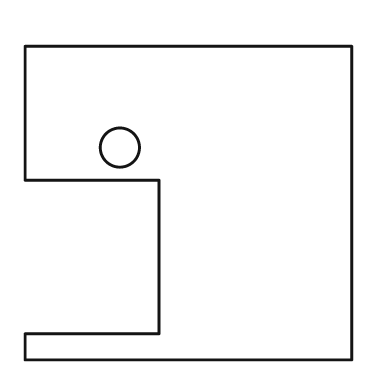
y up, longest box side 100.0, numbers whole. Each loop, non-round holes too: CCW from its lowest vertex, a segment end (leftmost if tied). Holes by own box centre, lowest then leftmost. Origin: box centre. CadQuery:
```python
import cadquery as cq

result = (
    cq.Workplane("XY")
    .moveTo(-50.0, -48.0)
    .lineTo(50.0, -48.0)
    .lineTo(50.0, 48.0)
    .lineTo(-50.0, 48.0)
    .lineTo(-50.0, 7.0)
    .lineTo(-9.0, 7.0)
    .lineTo(-9.0, -40.0)
    .lineTo(-50.0, -40.0)
    .close()
    .moveTo(-21.0, 17.0)
    .circle(6.0)
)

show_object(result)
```